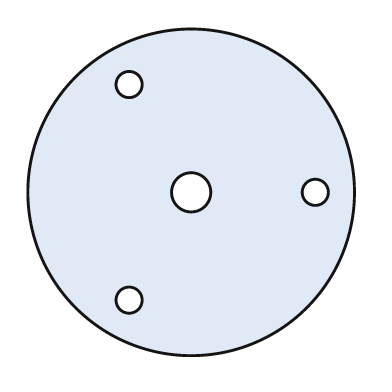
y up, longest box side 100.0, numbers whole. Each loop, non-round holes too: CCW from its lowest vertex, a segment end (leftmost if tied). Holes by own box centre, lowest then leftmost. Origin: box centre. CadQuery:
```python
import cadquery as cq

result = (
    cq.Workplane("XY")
    .moveTo(0.0, 0.0)
    .circle(50.0)
    .moveTo(-19.0, -33.0)
    .circle(4.0)
    .moveTo(0.0, 0.0)
    .circle(6.0)
    .moveTo(38.0, 0.0)
    .circle(4.0)
    .moveTo(-19.0, 33.0)
    .circle(4.0)
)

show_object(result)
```